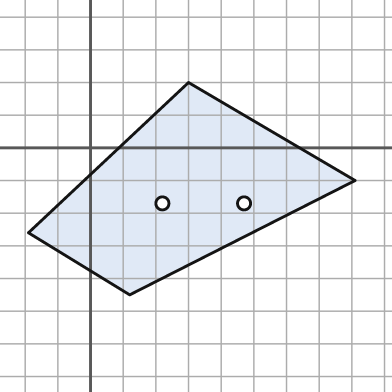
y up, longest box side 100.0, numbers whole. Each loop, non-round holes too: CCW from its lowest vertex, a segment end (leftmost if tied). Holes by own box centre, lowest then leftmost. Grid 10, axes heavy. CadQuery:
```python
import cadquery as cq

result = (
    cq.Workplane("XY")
    .moveTo(12.0, -45.0)
    .lineTo(81.0, -10.0)
    .lineTo(30.0, 20.0)
    .lineTo(-19.0, -26.0)
    .close()
    .moveTo(22.0, -17.0)
    .circle(2.0)
    .moveTo(47.0, -17.0)
    .circle(2.0)
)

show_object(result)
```